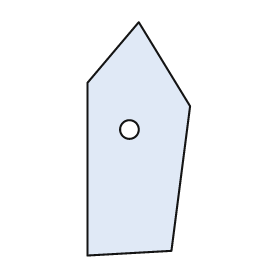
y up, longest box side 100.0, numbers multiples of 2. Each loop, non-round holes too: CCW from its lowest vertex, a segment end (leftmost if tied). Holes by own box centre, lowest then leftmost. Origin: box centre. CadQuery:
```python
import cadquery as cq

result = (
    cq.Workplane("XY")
    .moveTo(-22.0, -50.0)
    .lineTo(14.0, -48.0)
    .lineTo(22.0, 14.0)
    .lineTo(0.0, 50.0)
    .lineTo(-22.0, 24.0)
    .close()
    .moveTo(-4.0, 4.0)
    .circle(4.0)
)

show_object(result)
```